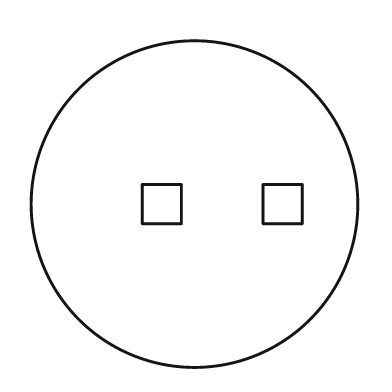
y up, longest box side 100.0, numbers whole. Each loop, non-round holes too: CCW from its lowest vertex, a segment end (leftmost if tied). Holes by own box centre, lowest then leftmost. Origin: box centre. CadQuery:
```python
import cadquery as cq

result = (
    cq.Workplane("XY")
    .moveTo(0.0, 0.0)
    .circle(50.0)
    .moveTo(-16.0, -6.0)
    .lineTo(-4.0, -6.0)
    .lineTo(-4.0, 6.0)
    .lineTo(-16.0, 6.0)
    .close()
    .moveTo(21.0, -6.0)
    .lineTo(33.0, -6.0)
    .lineTo(33.0, 6.0)
    .lineTo(21.0, 6.0)
    .close()
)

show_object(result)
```